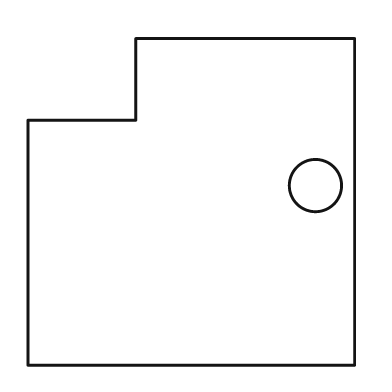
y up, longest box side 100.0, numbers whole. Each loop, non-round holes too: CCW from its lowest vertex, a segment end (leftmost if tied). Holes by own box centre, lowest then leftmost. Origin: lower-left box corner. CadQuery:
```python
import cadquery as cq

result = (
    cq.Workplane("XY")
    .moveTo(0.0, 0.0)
    .lineTo(100.0, 0.0)
    .lineTo(100.0, 100.0)
    .lineTo(33.0, 100.0)
    .lineTo(33.0, 75.0)
    .lineTo(0.0, 75.0)
    .close()
    .moveTo(88.0, 55.0)
    .circle(8.0)
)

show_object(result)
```